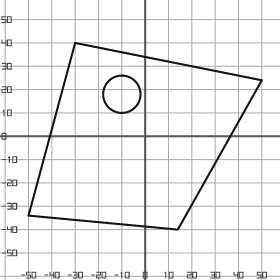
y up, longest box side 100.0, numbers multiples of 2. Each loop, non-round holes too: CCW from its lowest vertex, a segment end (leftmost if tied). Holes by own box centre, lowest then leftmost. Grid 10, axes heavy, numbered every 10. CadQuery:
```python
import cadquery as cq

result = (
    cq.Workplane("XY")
    .moveTo(14.0, -40.0)
    .lineTo(50.0, 24.0)
    .lineTo(-30.0, 40.0)
    .lineTo(-50.0, -34.0)
    .close()
    .moveTo(-10.0, 18.0)
    .circle(8.0)
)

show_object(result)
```